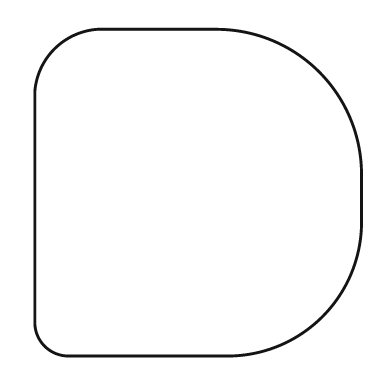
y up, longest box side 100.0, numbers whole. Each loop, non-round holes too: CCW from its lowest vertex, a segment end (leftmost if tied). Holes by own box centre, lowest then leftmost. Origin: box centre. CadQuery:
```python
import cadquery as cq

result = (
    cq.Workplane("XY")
    .moveTo(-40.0, -50.0)
    .lineTo(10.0, -50.0)
    .threePointArc((38.0, -38.0), (50.0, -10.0))
    .lineTo(50.0, 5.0)
    .threePointArc((37.0, 37.0), (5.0, 50.0))
    .lineTo(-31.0, 50.0)
    .threePointArc((-44.0, 44.0), (-50.0, 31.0))
    .lineTo(-50.0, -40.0)
    .threePointArc((-47.0, -47.0), (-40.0, -50.0))
    .close()
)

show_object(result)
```